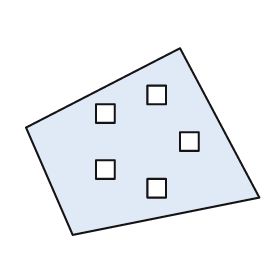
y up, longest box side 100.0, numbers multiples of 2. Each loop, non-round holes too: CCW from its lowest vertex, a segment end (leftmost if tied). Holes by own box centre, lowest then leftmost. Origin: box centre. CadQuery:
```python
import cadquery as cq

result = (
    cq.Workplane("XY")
    .moveTo(-30.0, -40.0)
    .lineTo(50.0, -24.0)
    .lineTo(16.0, 40.0)
    .lineTo(-50.0, 6.0)
    .close()
    .moveTo(2.0, -24.0)
    .lineTo(10.0, -24.0)
    .lineTo(10.0, -16.0)
    .lineTo(2.0, -16.0)
    .close()
    .moveTo(-20.0, -16.0)
    .lineTo(-12.0, -16.0)
    .lineTo(-12.0, -8.0)
    .lineTo(-20.0, -8.0)
    .close()
    .moveTo(16.0, -4.0)
    .lineTo(24.0, -4.0)
    .lineTo(24.0, 4.0)
    .lineTo(16.0, 4.0)
    .close()
    .moveTo(-20.0, 8.0)
    .lineTo(-12.0, 8.0)
    .lineTo(-12.0, 16.0)
    .lineTo(-20.0, 16.0)
    .close()
    .moveTo(2.0, 16.0)
    .lineTo(10.0, 16.0)
    .lineTo(10.0, 24.0)
    .lineTo(2.0, 24.0)
    .close()
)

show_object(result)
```